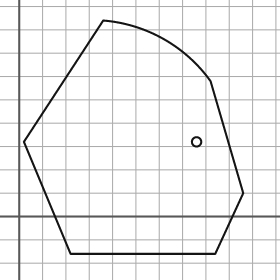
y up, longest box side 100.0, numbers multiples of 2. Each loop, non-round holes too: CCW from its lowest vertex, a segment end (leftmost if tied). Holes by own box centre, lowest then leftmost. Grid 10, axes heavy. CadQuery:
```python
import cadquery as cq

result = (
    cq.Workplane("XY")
    .moveTo(22.0, -16.0)
    .lineTo(84.0, -16.0)
    .lineTo(96.0, 10.0)
    .lineTo(82.0, 58.0)
    .threePointArc((62.0, 76.0), (36.0, 84.0))
    .lineTo(2.0, 32.0)
    .close()
    .moveTo(76.0, 32.0)
    .circle(2.0)
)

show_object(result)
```